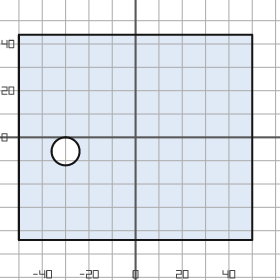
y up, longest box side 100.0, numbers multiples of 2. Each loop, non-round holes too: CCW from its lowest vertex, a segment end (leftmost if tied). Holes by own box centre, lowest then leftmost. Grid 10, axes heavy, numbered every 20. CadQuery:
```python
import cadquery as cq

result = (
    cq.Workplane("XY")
    .moveTo(-50.0, -44.0)
    .lineTo(50.0, -44.0)
    .lineTo(50.0, 44.0)
    .lineTo(-50.0, 44.0)
    .close()
    .moveTo(-30.0, -6.0)
    .circle(6.0)
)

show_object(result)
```